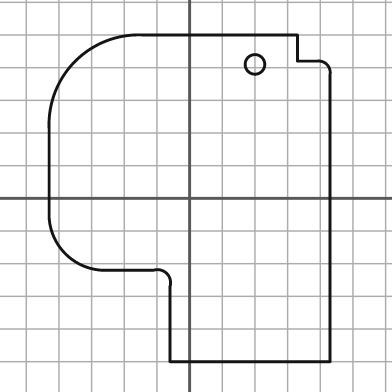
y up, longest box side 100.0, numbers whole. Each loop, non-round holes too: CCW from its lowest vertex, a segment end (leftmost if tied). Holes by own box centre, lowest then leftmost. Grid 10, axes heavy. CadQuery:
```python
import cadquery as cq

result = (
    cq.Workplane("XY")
    .moveTo(-6.0, -50.0)
    .lineTo(43.0, -50.0)
    .lineTo(43.0, 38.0)
    .threePointArc((42.0, 41.0), (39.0, 42.0))
    .lineTo(33.0, 42.0)
    .lineTo(33.0, 50.0)
    .lineTo(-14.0, 50.0)
    .threePointArc((-35.0, 42.0), (-43.0, 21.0))
    .lineTo(-43.0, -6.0)
    .threePointArc((-38.0, -17.0), (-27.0, -22.0))
    .lineTo(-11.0, -22.0)
    .threePointArc((-7.0, -23.0), (-6.0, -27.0))
    .close()
    .moveTo(20.0, 41.0)
    .circle(3.0)
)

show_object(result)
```